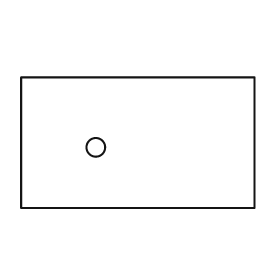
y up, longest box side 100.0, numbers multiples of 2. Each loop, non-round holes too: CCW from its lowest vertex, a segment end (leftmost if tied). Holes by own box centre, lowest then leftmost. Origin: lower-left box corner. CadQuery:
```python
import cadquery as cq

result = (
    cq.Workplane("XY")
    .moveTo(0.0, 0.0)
    .lineTo(100.0, 0.0)
    .lineTo(100.0, 56.0)
    .lineTo(0.0, 56.0)
    .close()
    .moveTo(32.0, 26.0)
    .circle(4.0)
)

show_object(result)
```